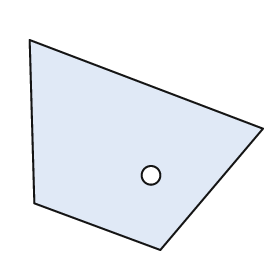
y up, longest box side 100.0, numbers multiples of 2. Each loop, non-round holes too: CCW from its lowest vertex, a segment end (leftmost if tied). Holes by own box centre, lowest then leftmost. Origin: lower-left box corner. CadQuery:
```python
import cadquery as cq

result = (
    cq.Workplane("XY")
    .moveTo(56.0, 0.0)
    .lineTo(100.0, 52.0)
    .lineTo(0.0, 90.0)
    .lineTo(2.0, 20.0)
    .close()
    .moveTo(52.0, 32.0)
    .circle(4.0)
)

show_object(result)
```